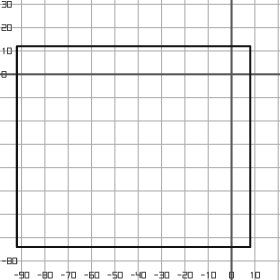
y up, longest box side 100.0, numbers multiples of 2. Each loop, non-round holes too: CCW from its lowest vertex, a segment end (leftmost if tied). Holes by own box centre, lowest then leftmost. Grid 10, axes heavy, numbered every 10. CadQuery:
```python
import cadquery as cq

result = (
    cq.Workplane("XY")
    .moveTo(-92.0, -74.0)
    .lineTo(8.0, -74.0)
    .lineTo(8.0, 12.0)
    .lineTo(-92.0, 12.0)
    .close()
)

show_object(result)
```